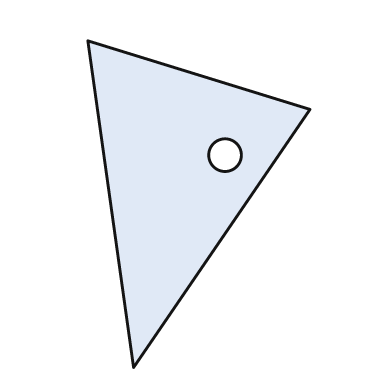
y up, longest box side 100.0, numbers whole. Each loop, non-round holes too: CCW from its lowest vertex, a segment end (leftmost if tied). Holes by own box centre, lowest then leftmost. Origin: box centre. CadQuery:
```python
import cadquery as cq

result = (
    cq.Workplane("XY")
    .moveTo(-20.0, -50.0)
    .lineTo(34.0, 29.0)
    .lineTo(-34.0, 50.0)
    .close()
    .moveTo(8.0, 15.0)
    .circle(5.0)
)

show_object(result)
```